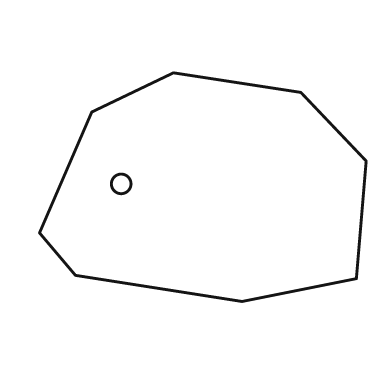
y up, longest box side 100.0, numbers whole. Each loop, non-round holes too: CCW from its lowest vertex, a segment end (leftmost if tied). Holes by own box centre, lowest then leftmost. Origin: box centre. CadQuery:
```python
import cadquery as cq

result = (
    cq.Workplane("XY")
    .moveTo(12.0, -35.0)
    .lineTo(47.0, -28.0)
    .lineTo(50.0, 8.0)
    .lineTo(30.0, 29.0)
    .lineTo(-9.0, 35.0)
    .lineTo(-34.0, 23.0)
    .lineTo(-50.0, -14.0)
    .lineTo(-39.0, -27.0)
    .close()
    .moveTo(-25.0, 1.0)
    .circle(3.0)
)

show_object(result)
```